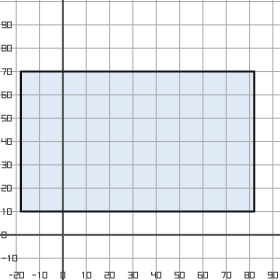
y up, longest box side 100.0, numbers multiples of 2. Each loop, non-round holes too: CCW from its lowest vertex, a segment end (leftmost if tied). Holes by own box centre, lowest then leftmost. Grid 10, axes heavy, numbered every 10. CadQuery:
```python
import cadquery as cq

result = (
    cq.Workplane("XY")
    .moveTo(-18.0, 10.0)
    .lineTo(82.0, 10.0)
    .lineTo(82.0, 70.0)
    .lineTo(-18.0, 70.0)
    .close()
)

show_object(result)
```